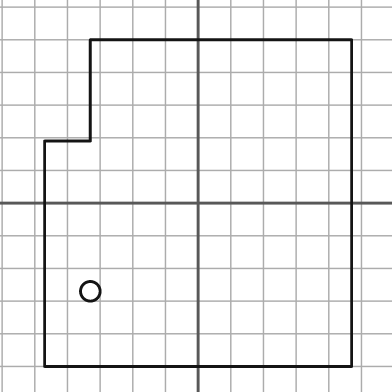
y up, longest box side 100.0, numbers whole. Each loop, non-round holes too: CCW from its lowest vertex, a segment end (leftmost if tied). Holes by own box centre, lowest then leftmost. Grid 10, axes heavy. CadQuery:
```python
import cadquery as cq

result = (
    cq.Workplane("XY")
    .moveTo(-47.0, -50.0)
    .lineTo(47.0, -50.0)
    .lineTo(47.0, 50.0)
    .lineTo(-33.0, 50.0)
    .lineTo(-33.0, 19.0)
    .lineTo(-47.0, 19.0)
    .close()
    .moveTo(-33.0, -27.0)
    .circle(3.0)
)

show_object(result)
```